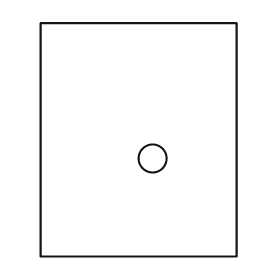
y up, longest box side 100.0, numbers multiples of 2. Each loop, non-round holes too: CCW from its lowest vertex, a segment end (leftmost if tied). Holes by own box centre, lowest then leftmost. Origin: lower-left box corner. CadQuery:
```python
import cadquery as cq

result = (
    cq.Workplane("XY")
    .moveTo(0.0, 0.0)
    .lineTo(84.0, 0.0)
    .lineTo(84.0, 100.0)
    .lineTo(0.0, 100.0)
    .close()
    .moveTo(48.0, 42.0)
    .circle(6.0)
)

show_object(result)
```